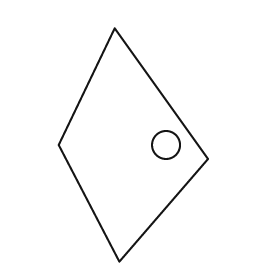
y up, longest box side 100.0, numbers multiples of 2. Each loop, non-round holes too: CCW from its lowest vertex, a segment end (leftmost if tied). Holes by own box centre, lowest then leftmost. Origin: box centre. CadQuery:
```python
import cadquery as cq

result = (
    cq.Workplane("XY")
    .moveTo(-6.0, -50.0)
    .lineTo(32.0, -6.0)
    .lineTo(-8.0, 50.0)
    .lineTo(-32.0, 0.0)
    .close()
    .moveTo(14.0, 0.0)
    .circle(6.0)
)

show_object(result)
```